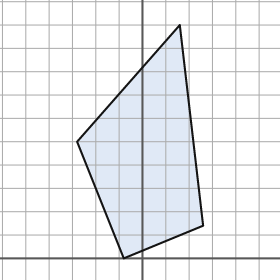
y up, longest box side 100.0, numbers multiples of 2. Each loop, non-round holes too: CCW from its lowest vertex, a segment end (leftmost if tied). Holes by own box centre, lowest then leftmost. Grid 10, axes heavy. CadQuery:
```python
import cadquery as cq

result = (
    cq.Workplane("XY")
    .moveTo(-8.0, 0.0)
    .lineTo(26.0, 14.0)
    .lineTo(16.0, 100.0)
    .lineTo(-28.0, 50.0)
    .close()
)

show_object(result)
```